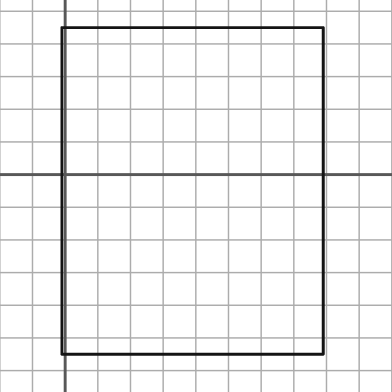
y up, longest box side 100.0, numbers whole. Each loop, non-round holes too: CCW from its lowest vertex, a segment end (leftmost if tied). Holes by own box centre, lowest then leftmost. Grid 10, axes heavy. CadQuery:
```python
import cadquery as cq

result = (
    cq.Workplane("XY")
    .moveTo(-1.0, -55.0)
    .lineTo(79.0, -55.0)
    .lineTo(79.0, 45.0)
    .lineTo(-1.0, 45.0)
    .close()
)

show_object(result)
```